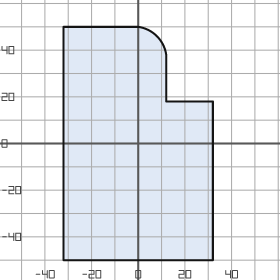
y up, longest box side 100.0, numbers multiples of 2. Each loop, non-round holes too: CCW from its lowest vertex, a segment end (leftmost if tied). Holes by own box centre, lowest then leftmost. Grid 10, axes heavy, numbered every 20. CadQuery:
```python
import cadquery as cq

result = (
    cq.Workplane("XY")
    .moveTo(-32.0, -50.0)
    .lineTo(32.0, -50.0)
    .lineTo(32.0, 18.0)
    .lineTo(12.0, 18.0)
    .lineTo(12.0, 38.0)
    .threePointArc((8.0, 46.0), (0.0, 50.0))
    .lineTo(-32.0, 50.0)
    .close()
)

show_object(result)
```